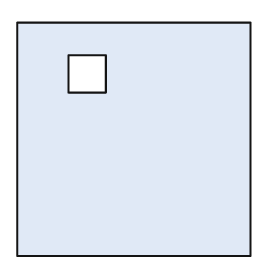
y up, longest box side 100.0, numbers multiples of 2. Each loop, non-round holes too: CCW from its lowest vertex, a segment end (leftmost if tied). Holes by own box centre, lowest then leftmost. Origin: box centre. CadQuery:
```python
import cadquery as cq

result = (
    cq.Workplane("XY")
    .moveTo(-50.0, -50.0)
    .lineTo(50.0, -50.0)
    .lineTo(50.0, 50.0)
    .lineTo(-50.0, 50.0)
    .close()
    .moveTo(-28.0, 20.0)
    .lineTo(-12.0, 20.0)
    .lineTo(-12.0, 36.0)
    .lineTo(-28.0, 36.0)
    .close()
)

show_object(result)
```